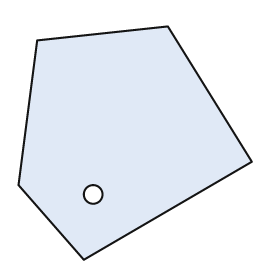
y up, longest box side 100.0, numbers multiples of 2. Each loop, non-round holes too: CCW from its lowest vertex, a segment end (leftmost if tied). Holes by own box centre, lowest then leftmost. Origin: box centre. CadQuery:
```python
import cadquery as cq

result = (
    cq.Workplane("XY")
    .moveTo(-22.0, -50.0)
    .lineTo(50.0, -8.0)
    .lineTo(14.0, 50.0)
    .lineTo(-42.0, 44.0)
    .lineTo(-50.0, -18.0)
    .close()
    .moveTo(-18.0, -22.0)
    .circle(4.0)
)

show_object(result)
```